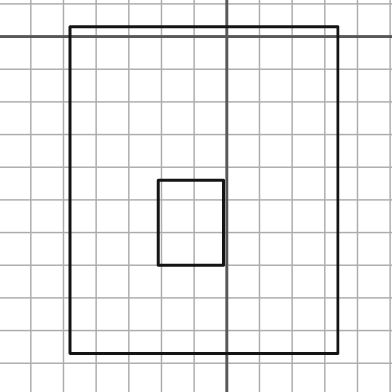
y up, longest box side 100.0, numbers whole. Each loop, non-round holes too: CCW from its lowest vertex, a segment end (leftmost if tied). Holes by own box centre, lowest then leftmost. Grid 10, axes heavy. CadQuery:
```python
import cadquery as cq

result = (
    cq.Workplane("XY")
    .moveTo(-48.0, -97.0)
    .lineTo(34.0, -97.0)
    .lineTo(34.0, 3.0)
    .lineTo(-48.0, 3.0)
    .close()
    .moveTo(-21.0, -70.0)
    .lineTo(-1.0, -70.0)
    .lineTo(-1.0, -44.0)
    .lineTo(-21.0, -44.0)
    .close()
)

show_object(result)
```